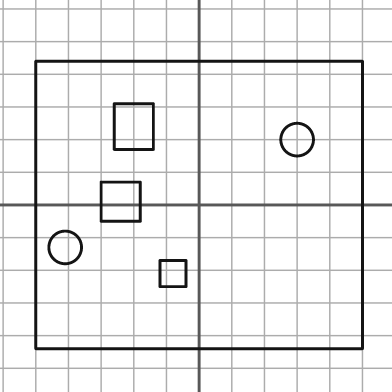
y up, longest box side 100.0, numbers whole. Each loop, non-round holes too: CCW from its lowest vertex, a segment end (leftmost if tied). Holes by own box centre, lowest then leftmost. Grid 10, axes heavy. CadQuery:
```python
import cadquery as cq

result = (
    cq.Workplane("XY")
    .moveTo(-50.0, -44.0)
    .lineTo(50.0, -44.0)
    .lineTo(50.0, 44.0)
    .lineTo(-50.0, 44.0)
    .close()
    .moveTo(-12.0, -25.0)
    .lineTo(-4.0, -25.0)
    .lineTo(-4.0, -17.0)
    .lineTo(-12.0, -17.0)
    .close()
    .moveTo(-41.0, -13.0)
    .circle(5.0)
    .moveTo(-30.0, -5.0)
    .lineTo(-18.0, -5.0)
    .lineTo(-18.0, 7.0)
    .lineTo(-30.0, 7.0)
    .close()
    .moveTo(30.0, 20.0)
    .circle(5.0)
    .moveTo(-26.0, 17.0)
    .lineTo(-14.0, 17.0)
    .lineTo(-14.0, 31.0)
    .lineTo(-26.0, 31.0)
    .close()
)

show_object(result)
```